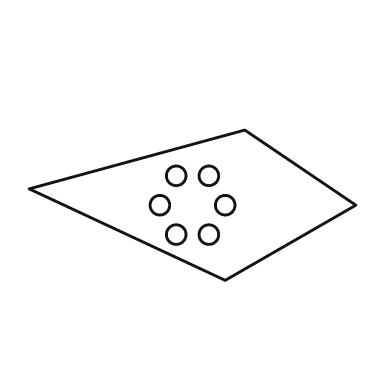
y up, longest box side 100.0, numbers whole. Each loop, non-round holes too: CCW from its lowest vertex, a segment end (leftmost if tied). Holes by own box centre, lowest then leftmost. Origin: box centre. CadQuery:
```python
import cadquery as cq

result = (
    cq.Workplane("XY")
    .moveTo(10.0, -23.0)
    .lineTo(50.0, 0.0)
    .lineTo(16.0, 23.0)
    .lineTo(-50.0, 5.0)
    .close()
    .moveTo(-5.0, -9.0)
    .circle(3.0)
    .moveTo(5.0, -9.0)
    .circle(3.0)
    .moveTo(-10.0, 0.0)
    .circle(3.0)
    .moveTo(10.0, 0.0)
    .circle(3.0)
    .moveTo(-5.0, 9.0)
    .circle(3.0)
    .moveTo(5.0, 9.0)
    .circle(3.0)
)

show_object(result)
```